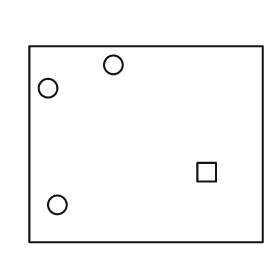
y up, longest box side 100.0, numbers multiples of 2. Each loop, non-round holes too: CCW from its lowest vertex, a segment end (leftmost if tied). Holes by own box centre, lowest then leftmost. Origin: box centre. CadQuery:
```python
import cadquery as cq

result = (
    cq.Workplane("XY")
    .moveTo(-50.0, -42.0)
    .lineTo(50.0, -42.0)
    .lineTo(50.0, 42.0)
    .lineTo(-50.0, 42.0)
    .close()
    .moveTo(-38.0, -26.0)
    .circle(4.0)
    .moveTo(22.0, -16.0)
    .lineTo(30.0, -16.0)
    .lineTo(30.0, -8.0)
    .lineTo(22.0, -8.0)
    .close()
    .moveTo(-42.0, 24.0)
    .circle(4.0)
    .moveTo(-14.0, 34.0)
    .circle(4.0)
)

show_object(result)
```